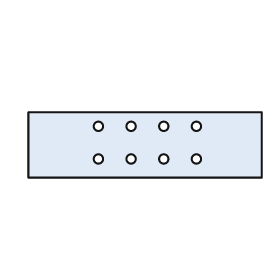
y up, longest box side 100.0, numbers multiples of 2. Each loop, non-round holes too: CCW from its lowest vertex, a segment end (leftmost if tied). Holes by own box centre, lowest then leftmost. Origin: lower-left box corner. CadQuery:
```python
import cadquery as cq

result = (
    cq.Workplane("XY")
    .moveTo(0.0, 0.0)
    .lineTo(100.0, 0.0)
    .lineTo(100.0, 28.0)
    .lineTo(0.0, 28.0)
    .close()
    .moveTo(30.0, 8.0)
    .circle(2.0)
    .moveTo(44.0, 8.0)
    .circle(2.0)
    .moveTo(58.0, 8.0)
    .circle(2.0)
    .moveTo(72.0, 8.0)
    .circle(2.0)
    .moveTo(30.0, 22.0)
    .circle(2.0)
    .moveTo(44.0, 22.0)
    .circle(2.0)
    .moveTo(58.0, 22.0)
    .circle(2.0)
    .moveTo(72.0, 22.0)
    .circle(2.0)
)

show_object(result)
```